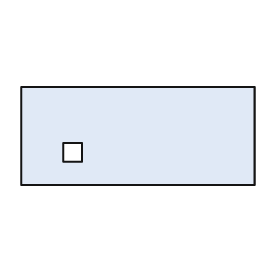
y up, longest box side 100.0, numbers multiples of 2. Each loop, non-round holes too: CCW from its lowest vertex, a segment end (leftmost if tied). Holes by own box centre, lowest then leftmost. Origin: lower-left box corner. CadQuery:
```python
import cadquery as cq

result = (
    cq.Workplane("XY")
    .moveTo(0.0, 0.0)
    .lineTo(100.0, 0.0)
    .lineTo(100.0, 42.0)
    .lineTo(0.0, 42.0)
    .close()
    .moveTo(18.0, 10.0)
    .lineTo(26.0, 10.0)
    .lineTo(26.0, 18.0)
    .lineTo(18.0, 18.0)
    .close()
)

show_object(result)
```